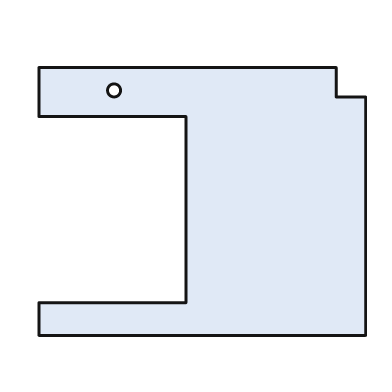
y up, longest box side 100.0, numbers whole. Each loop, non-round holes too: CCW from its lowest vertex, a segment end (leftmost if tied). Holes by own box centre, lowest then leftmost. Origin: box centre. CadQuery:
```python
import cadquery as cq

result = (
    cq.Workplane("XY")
    .moveTo(-50.0, -41.0)
    .lineTo(50.0, -41.0)
    .lineTo(50.0, 32.0)
    .lineTo(41.0, 32.0)
    .lineTo(41.0, 41.0)
    .lineTo(-50.0, 41.0)
    .lineTo(-50.0, 26.0)
    .lineTo(-5.0, 26.0)
    .lineTo(-5.0, -31.0)
    .lineTo(-50.0, -31.0)
    .close()
    .moveTo(-27.0, 34.0)
    .circle(2.0)
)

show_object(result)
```